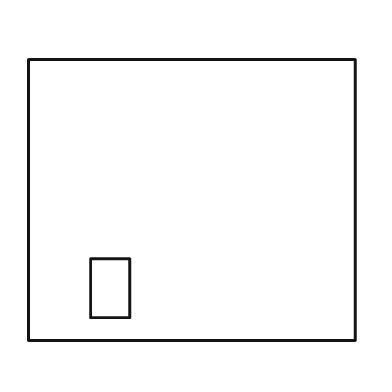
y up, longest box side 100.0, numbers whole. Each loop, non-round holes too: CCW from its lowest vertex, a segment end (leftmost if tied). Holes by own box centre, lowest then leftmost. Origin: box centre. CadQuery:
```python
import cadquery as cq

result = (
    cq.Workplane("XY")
    .moveTo(-50.0, -43.0)
    .lineTo(50.0, -43.0)
    .lineTo(50.0, 43.0)
    .lineTo(-50.0, 43.0)
    .close()
    .moveTo(-31.0, -36.0)
    .lineTo(-19.0, -36.0)
    .lineTo(-19.0, -18.0)
    .lineTo(-31.0, -18.0)
    .close()
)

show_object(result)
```